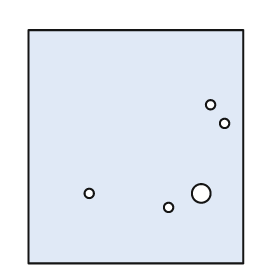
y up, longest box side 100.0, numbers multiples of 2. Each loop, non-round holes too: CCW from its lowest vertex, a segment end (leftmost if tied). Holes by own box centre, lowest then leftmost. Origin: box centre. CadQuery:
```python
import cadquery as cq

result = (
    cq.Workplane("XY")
    .moveTo(-46.0, -50.0)
    .lineTo(46.0, -50.0)
    .lineTo(46.0, 50.0)
    .lineTo(-46.0, 50.0)
    .close()
    .moveTo(14.0, -26.0)
    .circle(2.0)
    .moveTo(-20.0, -20.0)
    .circle(2.0)
    .moveTo(28.0, -20.0)
    .circle(4.0)
    .moveTo(38.0, 10.0)
    .circle(2.0)
    .moveTo(32.0, 18.0)
    .circle(2.0)
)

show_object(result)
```